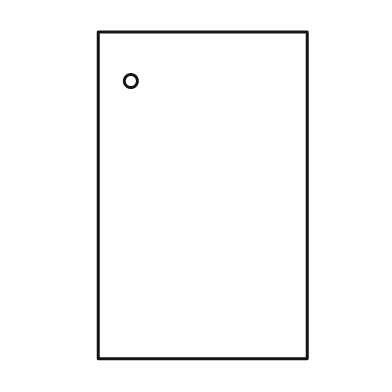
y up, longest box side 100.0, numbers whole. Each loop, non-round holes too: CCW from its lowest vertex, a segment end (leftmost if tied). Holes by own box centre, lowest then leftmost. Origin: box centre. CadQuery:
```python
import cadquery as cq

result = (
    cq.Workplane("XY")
    .moveTo(-32.0, -50.0)
    .lineTo(32.0, -50.0)
    .lineTo(32.0, 50.0)
    .lineTo(-32.0, 50.0)
    .close()
    .moveTo(-22.0, 35.0)
    .circle(2.0)
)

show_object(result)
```